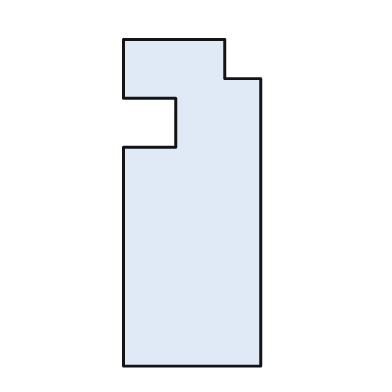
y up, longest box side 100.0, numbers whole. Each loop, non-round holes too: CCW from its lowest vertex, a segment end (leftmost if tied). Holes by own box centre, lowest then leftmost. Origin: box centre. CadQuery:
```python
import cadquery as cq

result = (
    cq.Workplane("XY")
    .moveTo(-21.0, -50.0)
    .lineTo(21.0, -50.0)
    .lineTo(21.0, 38.0)
    .lineTo(10.0, 38.0)
    .lineTo(10.0, 50.0)
    .lineTo(-21.0, 50.0)
    .lineTo(-21.0, 32.0)
    .lineTo(-5.0, 32.0)
    .lineTo(-5.0, 17.0)
    .lineTo(-21.0, 17.0)
    .close()
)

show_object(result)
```